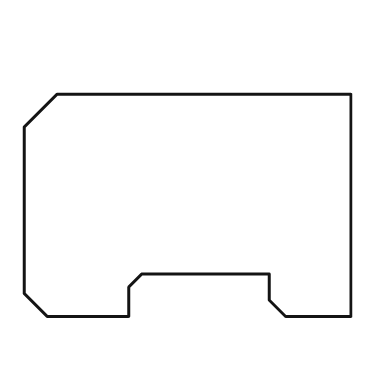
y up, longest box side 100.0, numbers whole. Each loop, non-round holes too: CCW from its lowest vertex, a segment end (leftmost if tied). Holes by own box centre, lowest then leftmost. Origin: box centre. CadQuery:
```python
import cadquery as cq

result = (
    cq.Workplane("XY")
    .moveTo(-43.0, -34.0)
    .lineTo(-18.0, -34.0)
    .lineTo(-18.0, -25.0)
    .lineTo(-14.0, -21.0)
    .lineTo(25.0, -21.0)
    .lineTo(25.0, -29.0)
    .lineTo(30.0, -34.0)
    .lineTo(50.0, -34.0)
    .lineTo(50.0, 34.0)
    .lineTo(-40.0, 34.0)
    .lineTo(-50.0, 24.0)
    .lineTo(-50.0, -27.0)
    .close()
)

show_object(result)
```